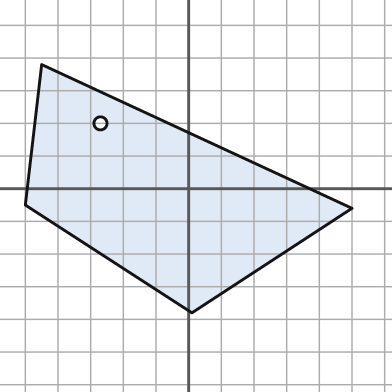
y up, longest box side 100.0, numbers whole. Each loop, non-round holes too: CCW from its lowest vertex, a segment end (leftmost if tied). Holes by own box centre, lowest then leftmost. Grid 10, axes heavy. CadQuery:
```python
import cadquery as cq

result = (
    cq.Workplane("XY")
    .moveTo(1.0, -38.0)
    .lineTo(50.0, -6.0)
    .lineTo(-45.0, 38.0)
    .lineTo(-50.0, -5.0)
    .close()
    .moveTo(-27.0, 20.0)
    .circle(2.0)
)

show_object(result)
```